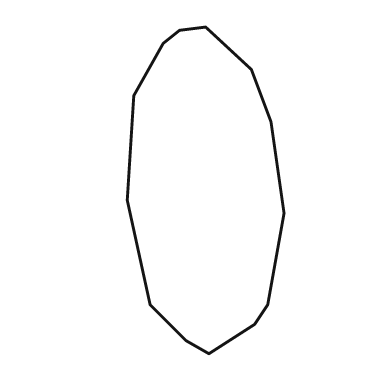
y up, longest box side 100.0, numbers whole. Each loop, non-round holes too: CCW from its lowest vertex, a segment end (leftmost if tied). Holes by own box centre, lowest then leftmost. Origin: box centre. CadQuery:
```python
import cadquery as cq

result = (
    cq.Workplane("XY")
    .moveTo(1.0, -50.0)
    .lineTo(15.0, -41.0)
    .lineTo(19.0, -35.0)
    .lineTo(24.0, -7.0)
    .lineTo(20.0, 21.0)
    .lineTo(14.0, 37.0)
    .lineTo(0.0, 50.0)
    .lineTo(-8.0, 49.0)
    .lineTo(-13.0, 45.0)
    .lineTo(-22.0, 29.0)
    .lineTo(-24.0, -3.0)
    .lineTo(-17.0, -35.0)
    .lineTo(-6.0, -46.0)
    .close()
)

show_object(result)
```